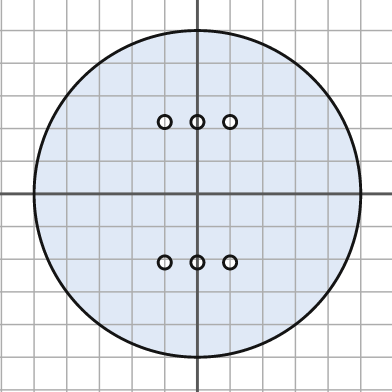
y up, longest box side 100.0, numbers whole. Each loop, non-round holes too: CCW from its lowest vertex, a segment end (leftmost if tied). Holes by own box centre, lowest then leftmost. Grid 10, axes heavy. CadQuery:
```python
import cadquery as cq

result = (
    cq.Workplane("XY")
    .moveTo(0.0, 0.0)
    .circle(50.0)
    .moveTo(-10.0, -21.0)
    .circle(2.0)
    .moveTo(0.0, -21.0)
    .circle(2.0)
    .moveTo(10.0, -21.0)
    .circle(2.0)
    .moveTo(-10.0, 22.0)
    .circle(2.0)
    .moveTo(0.0, 22.0)
    .circle(2.0)
    .moveTo(10.0, 22.0)
    .circle(2.0)
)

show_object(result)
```